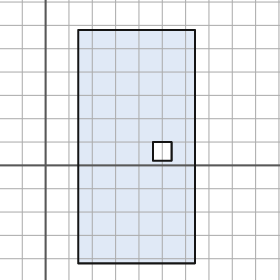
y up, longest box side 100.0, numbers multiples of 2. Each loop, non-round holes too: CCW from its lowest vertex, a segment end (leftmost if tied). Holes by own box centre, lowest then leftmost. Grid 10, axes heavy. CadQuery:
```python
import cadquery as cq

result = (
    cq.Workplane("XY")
    .moveTo(14.0, -42.0)
    .lineTo(64.0, -42.0)
    .lineTo(64.0, 58.0)
    .lineTo(14.0, 58.0)
    .close()
    .moveTo(46.0, 2.0)
    .lineTo(54.0, 2.0)
    .lineTo(54.0, 10.0)
    .lineTo(46.0, 10.0)
    .close()
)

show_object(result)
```